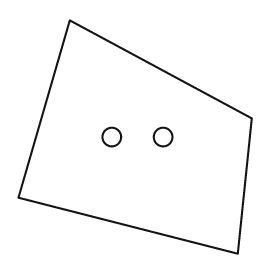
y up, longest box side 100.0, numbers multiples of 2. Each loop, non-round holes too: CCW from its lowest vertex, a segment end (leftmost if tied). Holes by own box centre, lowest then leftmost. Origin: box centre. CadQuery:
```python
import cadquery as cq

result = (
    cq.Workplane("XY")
    .moveTo(44.0, -50.0)
    .lineTo(50.0, 8.0)
    .lineTo(-28.0, 50.0)
    .lineTo(-50.0, -26.0)
    .close()
    .moveTo(-10.0, 0.0)
    .circle(4.0)
    .moveTo(12.0, 0.0)
    .circle(4.0)
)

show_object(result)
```